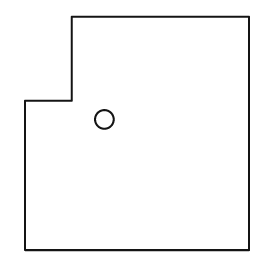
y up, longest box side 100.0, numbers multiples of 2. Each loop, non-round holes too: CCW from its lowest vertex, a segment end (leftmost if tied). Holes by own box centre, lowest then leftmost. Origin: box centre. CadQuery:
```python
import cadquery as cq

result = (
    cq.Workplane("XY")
    .moveTo(-48.0, -50.0)
    .lineTo(48.0, -50.0)
    .lineTo(48.0, 50.0)
    .lineTo(-28.0, 50.0)
    .lineTo(-28.0, 14.0)
    .lineTo(-48.0, 14.0)
    .close()
    .moveTo(-14.0, 6.0)
    .circle(4.0)
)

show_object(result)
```